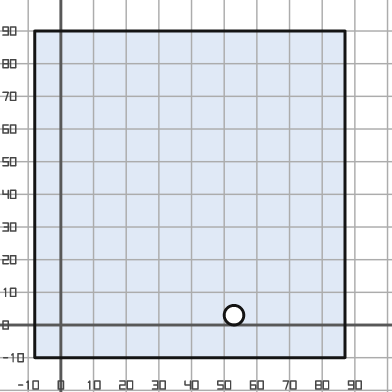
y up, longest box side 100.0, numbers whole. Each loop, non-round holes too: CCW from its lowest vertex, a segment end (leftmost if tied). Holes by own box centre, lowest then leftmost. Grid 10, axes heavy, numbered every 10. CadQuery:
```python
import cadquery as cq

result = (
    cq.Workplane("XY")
    .moveTo(-8.0, -10.0)
    .lineTo(87.0, -10.0)
    .lineTo(87.0, 90.0)
    .lineTo(-8.0, 90.0)
    .close()
    .moveTo(53.0, 3.0)
    .circle(3.0)
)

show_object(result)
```